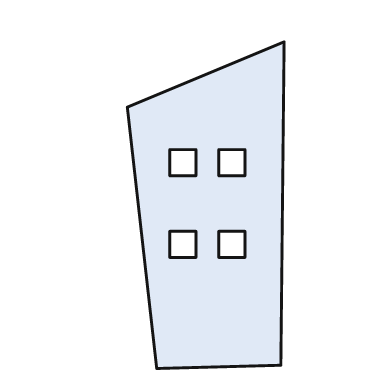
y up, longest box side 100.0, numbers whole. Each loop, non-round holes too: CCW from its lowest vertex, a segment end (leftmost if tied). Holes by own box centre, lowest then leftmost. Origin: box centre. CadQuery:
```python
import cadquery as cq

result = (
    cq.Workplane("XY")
    .moveTo(-15.0, -50.0)
    .lineTo(23.0, -49.0)
    .lineTo(24.0, 50.0)
    .lineTo(-24.0, 30.0)
    .close()
    .moveTo(-11.0, -16.0)
    .lineTo(-3.0, -16.0)
    .lineTo(-3.0, -8.0)
    .lineTo(-11.0, -8.0)
    .close()
    .moveTo(4.0, -16.0)
    .lineTo(12.0, -16.0)
    .lineTo(12.0, -8.0)
    .lineTo(4.0, -8.0)
    .close()
    .moveTo(-11.0, 9.0)
    .lineTo(-3.0, 9.0)
    .lineTo(-3.0, 17.0)
    .lineTo(-11.0, 17.0)
    .close()
    .moveTo(4.0, 9.0)
    .lineTo(12.0, 9.0)
    .lineTo(12.0, 17.0)
    .lineTo(4.0, 17.0)
    .close()
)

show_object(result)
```